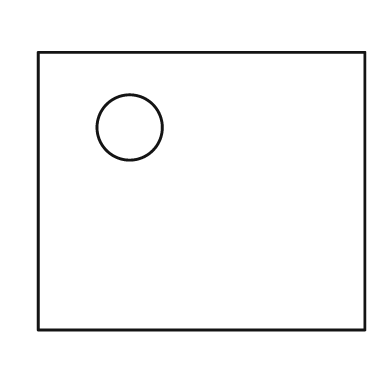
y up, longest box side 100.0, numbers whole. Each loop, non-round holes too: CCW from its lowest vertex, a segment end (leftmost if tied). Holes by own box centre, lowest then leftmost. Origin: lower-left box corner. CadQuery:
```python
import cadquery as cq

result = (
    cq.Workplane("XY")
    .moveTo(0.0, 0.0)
    .lineTo(100.0, 0.0)
    .lineTo(100.0, 85.0)
    .lineTo(0.0, 85.0)
    .close()
    .moveTo(28.0, 62.0)
    .circle(10.0)
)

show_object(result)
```